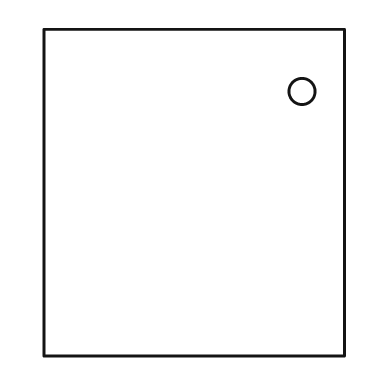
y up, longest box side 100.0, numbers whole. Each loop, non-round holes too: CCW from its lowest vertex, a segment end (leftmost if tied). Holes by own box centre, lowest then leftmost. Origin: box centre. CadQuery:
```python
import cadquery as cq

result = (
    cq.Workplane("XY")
    .moveTo(-46.0, -50.0)
    .lineTo(46.0, -50.0)
    .lineTo(46.0, 50.0)
    .lineTo(-46.0, 50.0)
    .close()
    .moveTo(33.0, 31.0)
    .circle(4.0)
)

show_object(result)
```